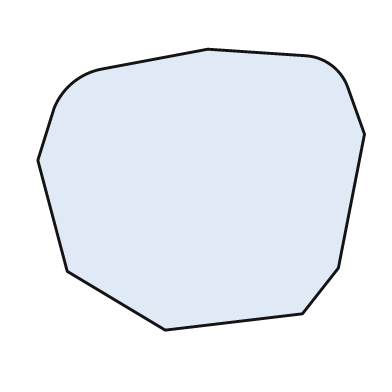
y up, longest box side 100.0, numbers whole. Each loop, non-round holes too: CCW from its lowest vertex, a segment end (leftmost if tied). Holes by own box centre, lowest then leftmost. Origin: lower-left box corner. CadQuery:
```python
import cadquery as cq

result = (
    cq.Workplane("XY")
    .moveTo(39.0, 0.0)
    .lineTo(81.0, 5.0)
    .lineTo(92.0, 19.0)
    .lineTo(100.0, 60.0)
    .lineTo(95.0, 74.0)
    .threePointArc((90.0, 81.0), (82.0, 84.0))
    .lineTo(52.0, 86.0)
    .lineTo(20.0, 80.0)
    .threePointArc((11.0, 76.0), (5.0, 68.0))
    .lineTo(0.0, 52.0)
    .lineTo(9.0, 18.0)
    .close()
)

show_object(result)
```